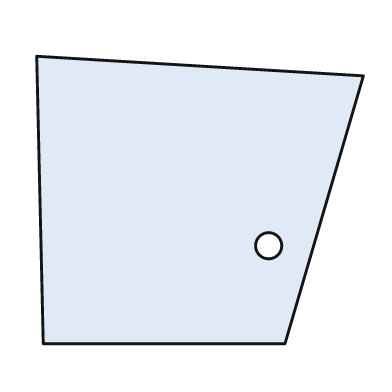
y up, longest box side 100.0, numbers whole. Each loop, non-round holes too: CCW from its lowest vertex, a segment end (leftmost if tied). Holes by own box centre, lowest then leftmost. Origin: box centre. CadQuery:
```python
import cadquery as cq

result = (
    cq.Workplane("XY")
    .moveTo(-48.0, -44.0)
    .lineTo(26.0, -44.0)
    .lineTo(50.0, 38.0)
    .lineTo(-50.0, 44.0)
    .close()
    .moveTo(21.0, -14.0)
    .circle(4.0)
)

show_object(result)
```